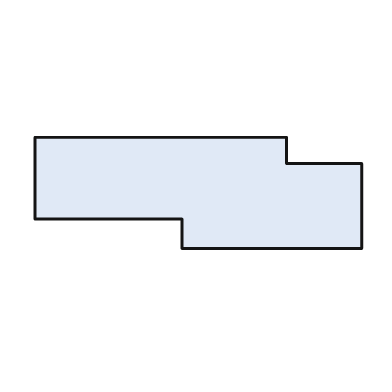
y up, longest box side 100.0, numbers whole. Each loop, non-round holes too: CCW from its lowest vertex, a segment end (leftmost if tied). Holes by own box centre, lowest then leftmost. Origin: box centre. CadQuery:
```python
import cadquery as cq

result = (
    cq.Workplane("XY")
    .moveTo(-5.0, -17.0)
    .lineTo(50.0, -17.0)
    .lineTo(50.0, 9.0)
    .lineTo(27.0, 9.0)
    .lineTo(27.0, 17.0)
    .lineTo(-50.0, 17.0)
    .lineTo(-50.0, -8.0)
    .lineTo(-5.0, -8.0)
    .close()
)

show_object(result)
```